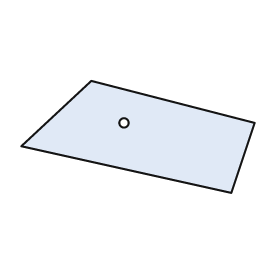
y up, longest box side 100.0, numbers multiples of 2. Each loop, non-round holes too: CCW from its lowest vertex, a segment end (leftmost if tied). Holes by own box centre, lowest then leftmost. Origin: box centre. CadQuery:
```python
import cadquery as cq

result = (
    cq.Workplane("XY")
    .moveTo(40.0, -24.0)
    .lineTo(50.0, 6.0)
    .lineTo(-20.0, 24.0)
    .lineTo(-50.0, -4.0)
    .close()
    .moveTo(-6.0, 6.0)
    .circle(2.0)
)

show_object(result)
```